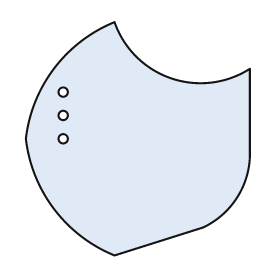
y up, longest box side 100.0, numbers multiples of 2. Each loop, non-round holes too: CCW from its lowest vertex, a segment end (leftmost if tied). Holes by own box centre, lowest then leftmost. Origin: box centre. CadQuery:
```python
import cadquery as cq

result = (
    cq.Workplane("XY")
    .moveTo(-10.0, -50.0)
    .lineTo(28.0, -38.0)
    .threePointArc((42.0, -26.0), (48.0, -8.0))
    .lineTo(48.0, 30.0)
    .threePointArc((14.0, 26.0), (-10.0, 50.0))
    .threePointArc((-36.0, 30.0), (-48.0, 0.0))
    .threePointArc((-36.0, -30.0), (-10.0, -50.0))
    .close()
    .moveTo(-32.0, 0.0)
    .circle(2.0)
    .moveTo(-32.0, 10.0)
    .circle(2.0)
    .moveTo(-32.0, 20.0)
    .circle(2.0)
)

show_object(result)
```